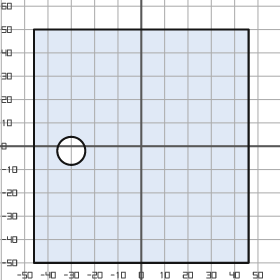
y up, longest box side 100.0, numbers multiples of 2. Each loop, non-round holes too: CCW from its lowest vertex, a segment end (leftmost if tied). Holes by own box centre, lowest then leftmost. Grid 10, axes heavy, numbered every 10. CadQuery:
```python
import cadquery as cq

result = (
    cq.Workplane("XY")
    .moveTo(-46.0, -50.0)
    .lineTo(46.0, -50.0)
    .lineTo(46.0, 50.0)
    .lineTo(-46.0, 50.0)
    .close()
    .moveTo(-30.0, -2.0)
    .circle(6.0)
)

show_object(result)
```